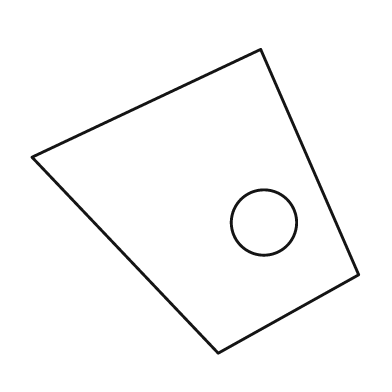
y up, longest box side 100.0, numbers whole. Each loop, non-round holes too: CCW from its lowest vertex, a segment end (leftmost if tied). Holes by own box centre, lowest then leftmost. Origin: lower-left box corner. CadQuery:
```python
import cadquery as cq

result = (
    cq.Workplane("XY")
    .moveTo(57.0, 0.0)
    .lineTo(100.0, 24.0)
    .lineTo(70.0, 93.0)
    .lineTo(0.0, 60.0)
    .close()
    .moveTo(71.0, 40.0)
    .circle(10.0)
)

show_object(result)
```